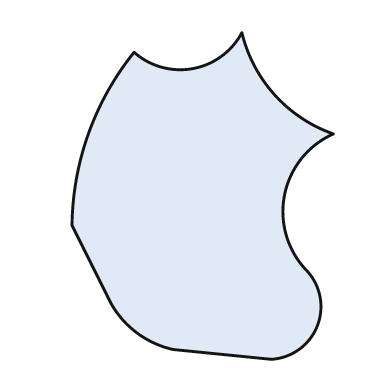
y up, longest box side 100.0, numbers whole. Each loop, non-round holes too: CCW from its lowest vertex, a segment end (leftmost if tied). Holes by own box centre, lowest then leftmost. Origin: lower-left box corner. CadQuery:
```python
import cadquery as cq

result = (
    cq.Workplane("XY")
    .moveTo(61.0, 0.0)
    .threePointArc((75.0, 10.0), (72.0, 27.0))
    .threePointArc((65.0, 50.0), (80.0, 69.0))
    .threePointArc((62.0, 81.0), (52.0, 100.0))
    .threePointArc((37.0, 89.0), (19.0, 94.0))
    .threePointArc((5.0, 69.0), (0.0, 41.0))
    .lineTo(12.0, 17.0)
    .threePointArc((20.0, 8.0), (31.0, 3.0))
    .close()
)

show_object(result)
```